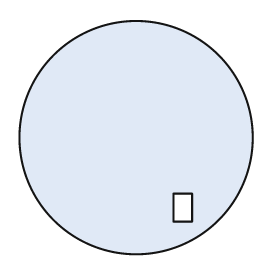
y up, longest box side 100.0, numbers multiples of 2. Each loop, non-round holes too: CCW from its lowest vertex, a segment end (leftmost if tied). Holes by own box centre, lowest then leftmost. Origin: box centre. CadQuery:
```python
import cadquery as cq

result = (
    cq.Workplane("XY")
    .moveTo(0.0, 0.0)
    .circle(50.0)
    .moveTo(16.0, -36.0)
    .lineTo(24.0, -36.0)
    .lineTo(24.0, -24.0)
    .lineTo(16.0, -24.0)
    .close()
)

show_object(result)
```